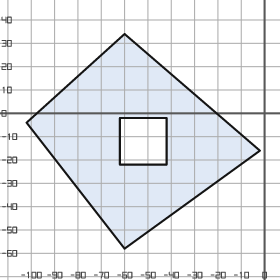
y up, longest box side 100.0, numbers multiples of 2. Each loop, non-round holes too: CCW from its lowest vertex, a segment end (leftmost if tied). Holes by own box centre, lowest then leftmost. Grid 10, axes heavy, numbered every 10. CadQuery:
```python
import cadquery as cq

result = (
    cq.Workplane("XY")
    .moveTo(-60.0, -58.0)
    .lineTo(-2.0, -16.0)
    .lineTo(-60.0, 34.0)
    .lineTo(-102.0, -4.0)
    .close()
    .moveTo(-62.0, -22.0)
    .lineTo(-42.0, -22.0)
    .lineTo(-42.0, -2.0)
    .lineTo(-62.0, -2.0)
    .close()
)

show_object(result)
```